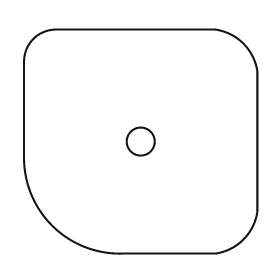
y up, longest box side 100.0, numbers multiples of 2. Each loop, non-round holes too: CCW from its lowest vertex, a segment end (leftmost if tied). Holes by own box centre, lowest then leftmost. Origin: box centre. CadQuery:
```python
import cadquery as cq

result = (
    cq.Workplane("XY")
    .moveTo(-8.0, -48.0)
    .lineTo(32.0, -48.0)
    .threePointArc((44.0, -42.0), (50.0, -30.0))
    .lineTo(50.0, 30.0)
    .threePointArc((44.0, 42.0), (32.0, 48.0))
    .lineTo(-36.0, 48.0)
    .threePointArc((-46.0, 44.0), (-50.0, 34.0))
    .lineTo(-50.0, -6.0)
    .threePointArc((-38.0, -36.0), (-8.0, -48.0))
    .close()
    .moveTo(0.0, 0.0)
    .circle(6.0)
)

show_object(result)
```